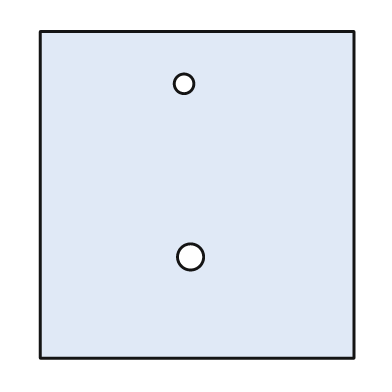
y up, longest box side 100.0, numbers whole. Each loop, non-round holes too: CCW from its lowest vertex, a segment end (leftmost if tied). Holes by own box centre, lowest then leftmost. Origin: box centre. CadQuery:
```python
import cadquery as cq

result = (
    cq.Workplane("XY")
    .moveTo(-48.0, -50.0)
    .lineTo(48.0, -50.0)
    .lineTo(48.0, 50.0)
    .lineTo(-48.0, 50.0)
    .close()
    .moveTo(-2.0, -19.0)
    .circle(4.0)
    .moveTo(-4.0, 34.0)
    .circle(3.0)
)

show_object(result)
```